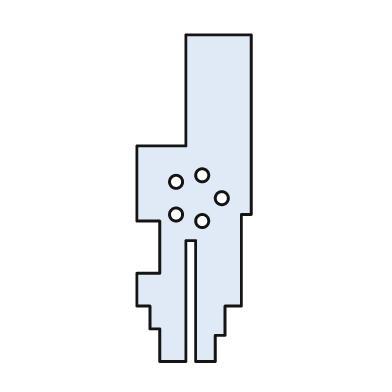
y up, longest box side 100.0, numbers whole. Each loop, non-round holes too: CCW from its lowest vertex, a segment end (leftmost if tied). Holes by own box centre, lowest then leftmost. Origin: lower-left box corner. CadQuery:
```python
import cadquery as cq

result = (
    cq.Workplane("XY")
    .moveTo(7.0, 0.0)
    .lineTo(15.0, 0.0)
    .lineTo(15.0, 37.0)
    .lineTo(18.0, 37.0)
    .lineTo(18.0, 0.0)
    .lineTo(24.0, 0.0)
    .lineTo(24.0, 8.0)
    .lineTo(27.0, 8.0)
    .lineTo(27.0, 17.0)
    .lineTo(32.0, 17.0)
    .lineTo(32.0, 45.0)
    .lineTo(35.0, 45.0)
    .lineTo(35.0, 100.0)
    .lineTo(15.0, 100.0)
    .lineTo(15.0, 66.0)
    .lineTo(0.0, 66.0)
    .lineTo(0.0, 43.0)
    .lineTo(7.0, 43.0)
    .lineTo(7.0, 27.0)
    .lineTo(0.0, 27.0)
    .lineTo(0.0, 17.0)
    .lineTo(4.0, 17.0)
    .lineTo(4.0, 10.0)
    .lineTo(7.0, 10.0)
    .close()
    .moveTo(20.0, 43.0)
    .circle(2.0)
    .moveTo(12.0, 45.0)
    .circle(2.0)
    .moveTo(26.0, 50.0)
    .circle(2.0)
    .moveTo(12.0, 55.0)
    .circle(2.0)
    .moveTo(20.0, 57.0)
    .circle(2.0)
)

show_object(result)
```